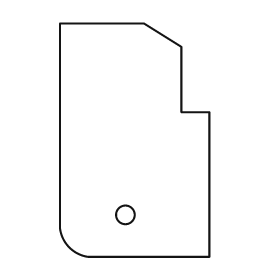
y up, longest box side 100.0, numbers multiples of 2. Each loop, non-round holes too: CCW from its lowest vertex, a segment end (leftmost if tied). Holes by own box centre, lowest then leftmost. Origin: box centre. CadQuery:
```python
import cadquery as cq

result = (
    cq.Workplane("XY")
    .moveTo(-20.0, -50.0)
    .lineTo(32.0, -50.0)
    .lineTo(32.0, 12.0)
    .lineTo(20.0, 12.0)
    .lineTo(20.0, 40.0)
    .lineTo(4.0, 50.0)
    .lineTo(-32.0, 50.0)
    .lineTo(-32.0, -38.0)
    .threePointArc((-28.0, -46.0), (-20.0, -50.0))
    .close()
    .moveTo(-4.0, -32.0)
    .circle(4.0)
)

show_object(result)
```